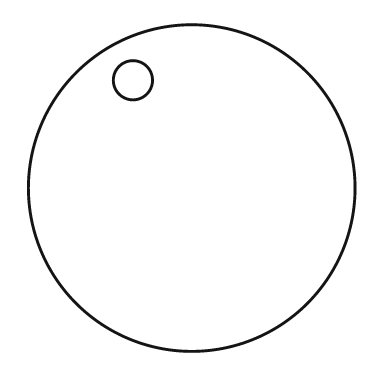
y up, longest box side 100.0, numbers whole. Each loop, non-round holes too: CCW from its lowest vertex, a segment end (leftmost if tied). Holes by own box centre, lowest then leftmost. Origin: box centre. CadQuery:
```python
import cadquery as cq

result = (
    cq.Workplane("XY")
    .moveTo(0.0, 0.0)
    .circle(50.0)
    .moveTo(-18.0, 33.0)
    .circle(6.0)
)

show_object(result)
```